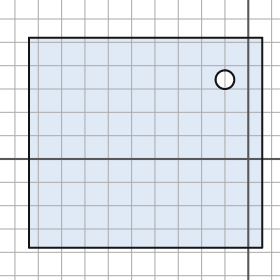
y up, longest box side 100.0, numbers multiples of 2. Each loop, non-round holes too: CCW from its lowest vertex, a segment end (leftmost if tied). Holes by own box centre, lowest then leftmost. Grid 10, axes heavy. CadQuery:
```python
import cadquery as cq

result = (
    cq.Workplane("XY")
    .moveTo(-94.0, -38.0)
    .lineTo(6.0, -38.0)
    .lineTo(6.0, 52.0)
    .lineTo(-94.0, 52.0)
    .close()
    .moveTo(-10.0, 34.0)
    .circle(4.0)
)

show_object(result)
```